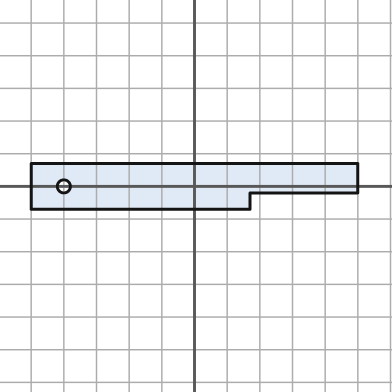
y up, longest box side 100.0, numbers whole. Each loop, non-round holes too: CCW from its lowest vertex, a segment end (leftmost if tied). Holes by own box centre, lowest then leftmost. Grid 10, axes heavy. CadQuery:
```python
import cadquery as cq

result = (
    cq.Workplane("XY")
    .moveTo(-50.0, -7.0)
    .lineTo(17.0, -7.0)
    .lineTo(17.0, -2.0)
    .lineTo(50.0, -2.0)
    .lineTo(50.0, 7.0)
    .lineTo(-50.0, 7.0)
    .close()
    .moveTo(-40.0, 0.0)
    .circle(2.0)
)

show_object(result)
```